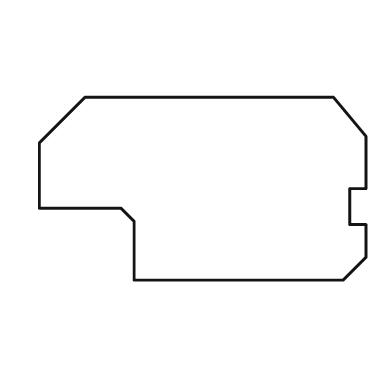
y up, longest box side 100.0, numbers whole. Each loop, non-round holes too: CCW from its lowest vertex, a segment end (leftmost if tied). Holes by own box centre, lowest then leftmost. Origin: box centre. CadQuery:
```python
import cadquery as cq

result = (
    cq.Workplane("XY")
    .moveTo(-21.0, -28.0)
    .lineTo(43.0, -28.0)
    .lineTo(50.0, -21.0)
    .lineTo(50.0, -11.0)
    .lineTo(45.0, -11.0)
    .lineTo(45.0, 0.0)
    .lineTo(50.0, 0.0)
    .lineTo(50.0, 16.0)
    .lineTo(40.0, 28.0)
    .lineTo(-36.0, 28.0)
    .lineTo(-50.0, 14.0)
    .lineTo(-50.0, -6.0)
    .lineTo(-25.0, -6.0)
    .lineTo(-21.0, -10.0)
    .close()
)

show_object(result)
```